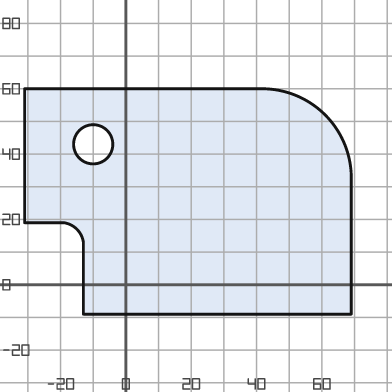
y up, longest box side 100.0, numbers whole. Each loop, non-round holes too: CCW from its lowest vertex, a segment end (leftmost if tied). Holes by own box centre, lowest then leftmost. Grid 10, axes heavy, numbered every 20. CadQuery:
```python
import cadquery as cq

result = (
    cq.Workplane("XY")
    .moveTo(-13.0, -9.0)
    .lineTo(69.0, -9.0)
    .lineTo(69.0, 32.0)
    .threePointArc((61.0, 52.0), (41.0, 60.0))
    .lineTo(-31.0, 60.0)
    .lineTo(-31.0, 19.0)
    .lineTo(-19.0, 19.0)
    .threePointArc((-15.0, 17.0), (-13.0, 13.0))
    .close()
    .moveTo(-10.0, 43.0)
    .circle(6.0)
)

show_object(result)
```